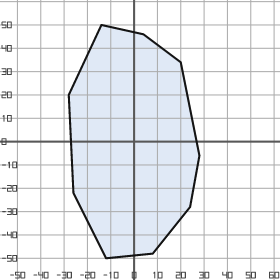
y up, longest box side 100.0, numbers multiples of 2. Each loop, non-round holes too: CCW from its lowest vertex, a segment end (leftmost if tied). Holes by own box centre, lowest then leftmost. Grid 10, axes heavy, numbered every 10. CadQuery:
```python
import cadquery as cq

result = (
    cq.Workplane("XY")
    .moveTo(-12.0, -50.0)
    .lineTo(8.0, -48.0)
    .lineTo(24.0, -28.0)
    .lineTo(28.0, -6.0)
    .lineTo(20.0, 34.0)
    .lineTo(4.0, 46.0)
    .lineTo(-14.0, 50.0)
    .lineTo(-28.0, 20.0)
    .lineTo(-26.0, -22.0)
    .close()
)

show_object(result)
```